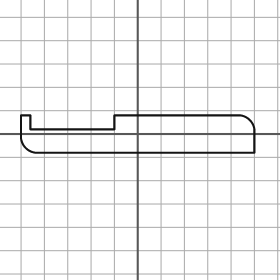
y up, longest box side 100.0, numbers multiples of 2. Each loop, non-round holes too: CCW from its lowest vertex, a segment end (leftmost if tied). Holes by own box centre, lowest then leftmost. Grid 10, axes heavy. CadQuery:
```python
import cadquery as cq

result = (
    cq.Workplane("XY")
    .moveTo(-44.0, -8.0)
    .lineTo(50.0, -8.0)
    .lineTo(50.0, 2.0)
    .threePointArc((48.0, 6.0), (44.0, 8.0))
    .lineTo(-10.0, 8.0)
    .lineTo(-10.0, 2.0)
    .lineTo(-46.0, 2.0)
    .lineTo(-46.0, 8.0)
    .lineTo(-50.0, 8.0)
    .lineTo(-50.0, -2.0)
    .threePointArc((-48.0, -6.0), (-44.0, -8.0))
    .close()
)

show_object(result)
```